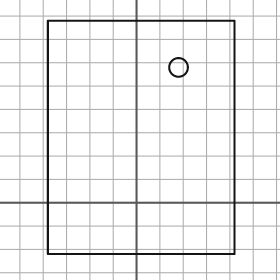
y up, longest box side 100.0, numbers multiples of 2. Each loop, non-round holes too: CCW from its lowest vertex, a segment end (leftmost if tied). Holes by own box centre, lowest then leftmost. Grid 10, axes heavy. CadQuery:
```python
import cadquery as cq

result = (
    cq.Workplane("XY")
    .moveTo(-38.0, -22.0)
    .lineTo(42.0, -22.0)
    .lineTo(42.0, 78.0)
    .lineTo(-38.0, 78.0)
    .close()
    .moveTo(18.0, 58.0)
    .circle(4.0)
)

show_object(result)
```